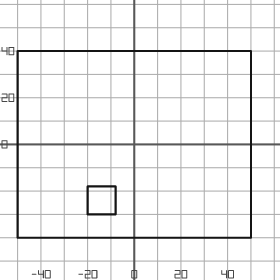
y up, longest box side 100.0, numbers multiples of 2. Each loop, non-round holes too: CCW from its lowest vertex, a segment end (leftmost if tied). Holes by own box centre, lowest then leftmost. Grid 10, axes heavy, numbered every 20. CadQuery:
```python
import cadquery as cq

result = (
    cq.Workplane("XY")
    .moveTo(-50.0, -40.0)
    .lineTo(50.0, -40.0)
    .lineTo(50.0, 40.0)
    .lineTo(-50.0, 40.0)
    .close()
    .moveTo(-20.0, -30.0)
    .lineTo(-8.0, -30.0)
    .lineTo(-8.0, -18.0)
    .lineTo(-20.0, -18.0)
    .close()
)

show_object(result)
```